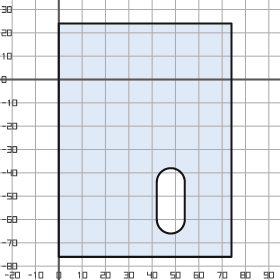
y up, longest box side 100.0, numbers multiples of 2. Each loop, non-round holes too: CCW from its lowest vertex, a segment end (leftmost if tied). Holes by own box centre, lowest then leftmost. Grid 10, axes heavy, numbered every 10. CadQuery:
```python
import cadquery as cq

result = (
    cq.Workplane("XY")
    .moveTo(0.0, -76.0)
    .lineTo(74.0, -76.0)
    .lineTo(74.0, 24.0)
    .lineTo(0.0, 24.0)
    .close()
    .moveTo(42.0, -60.0)
    .threePointArc((48.0, -66.0), (54.0, -60.0))
    .lineTo(54.0, -44.0)
    .threePointArc((48.0, -38.0), (42.0, -44.0))
    .close()
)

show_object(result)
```